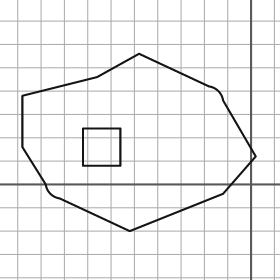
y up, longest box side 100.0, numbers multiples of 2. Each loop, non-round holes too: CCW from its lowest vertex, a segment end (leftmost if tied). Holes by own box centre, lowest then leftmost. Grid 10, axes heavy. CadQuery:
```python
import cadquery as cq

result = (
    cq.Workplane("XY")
    .moveTo(-52.0, -20.0)
    .lineTo(-12.0, -4.0)
    .lineTo(2.0, 12.0)
    .lineTo(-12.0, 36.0)
    .threePointArc((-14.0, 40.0), (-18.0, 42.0))
    .lineTo(-48.0, 56.0)
    .lineTo(-66.0, 46.0)
    .lineTo(-98.0, 38.0)
    .lineTo(-98.0, 16.0)
    .lineTo(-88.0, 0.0)
    .threePointArc((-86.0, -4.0), (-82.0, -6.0))
    .close()
    .moveTo(-72.0, 8.0)
    .lineTo(-56.0, 8.0)
    .lineTo(-56.0, 24.0)
    .lineTo(-72.0, 24.0)
    .close()
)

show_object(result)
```